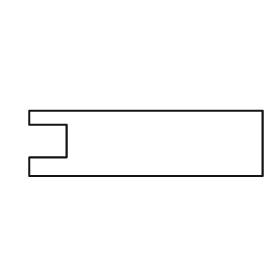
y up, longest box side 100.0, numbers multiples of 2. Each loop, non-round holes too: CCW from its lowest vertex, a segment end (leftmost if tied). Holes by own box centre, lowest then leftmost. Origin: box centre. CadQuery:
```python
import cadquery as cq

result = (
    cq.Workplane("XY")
    .moveTo(-50.0, -14.0)
    .lineTo(50.0, -14.0)
    .lineTo(50.0, 14.0)
    .lineTo(-50.0, 14.0)
    .lineTo(-50.0, 8.0)
    .lineTo(-34.0, 8.0)
    .lineTo(-34.0, -6.0)
    .lineTo(-50.0, -6.0)
    .close()
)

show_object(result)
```